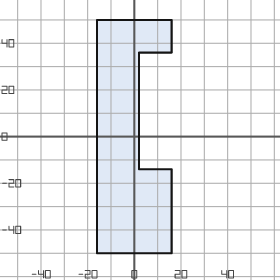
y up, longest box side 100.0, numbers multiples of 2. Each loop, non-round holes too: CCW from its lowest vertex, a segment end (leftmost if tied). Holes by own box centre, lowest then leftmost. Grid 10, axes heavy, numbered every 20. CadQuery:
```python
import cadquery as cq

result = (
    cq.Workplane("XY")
    .moveTo(-16.0, -50.0)
    .lineTo(16.0, -50.0)
    .lineTo(16.0, -14.0)
    .lineTo(2.0, -14.0)
    .lineTo(2.0, 36.0)
    .lineTo(16.0, 36.0)
    .lineTo(16.0, 50.0)
    .lineTo(-16.0, 50.0)
    .close()
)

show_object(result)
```